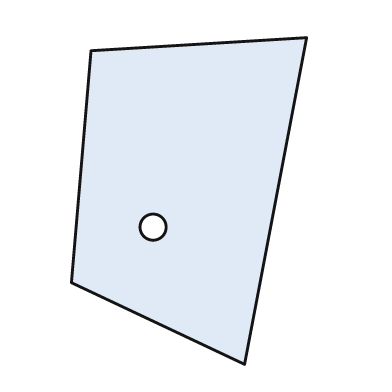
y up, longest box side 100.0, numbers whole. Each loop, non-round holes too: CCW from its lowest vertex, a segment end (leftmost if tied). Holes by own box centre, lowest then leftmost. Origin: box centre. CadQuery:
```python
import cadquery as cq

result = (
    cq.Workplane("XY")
    .moveTo(17.0, -50.0)
    .lineTo(36.0, 50.0)
    .lineTo(-30.0, 46.0)
    .lineTo(-36.0, -25.0)
    .close()
    .moveTo(-11.0, -8.0)
    .circle(4.0)
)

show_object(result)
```